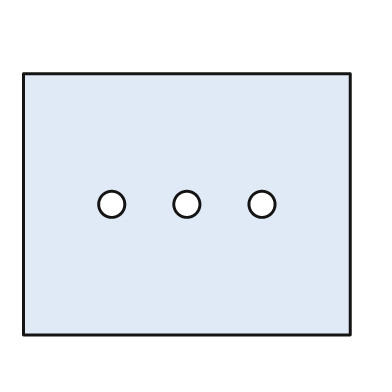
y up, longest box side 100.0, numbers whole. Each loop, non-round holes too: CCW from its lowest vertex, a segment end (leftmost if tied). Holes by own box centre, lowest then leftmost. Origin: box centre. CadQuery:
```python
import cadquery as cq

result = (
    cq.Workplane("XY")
    .moveTo(-50.0, -40.0)
    .lineTo(50.0, -40.0)
    .lineTo(50.0, 40.0)
    .lineTo(-50.0, 40.0)
    .close()
    .moveTo(-23.0, 0.0)
    .circle(4.0)
    .moveTo(0.0, 0.0)
    .circle(4.0)
    .moveTo(23.0, 0.0)
    .circle(4.0)
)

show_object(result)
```